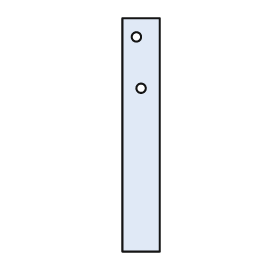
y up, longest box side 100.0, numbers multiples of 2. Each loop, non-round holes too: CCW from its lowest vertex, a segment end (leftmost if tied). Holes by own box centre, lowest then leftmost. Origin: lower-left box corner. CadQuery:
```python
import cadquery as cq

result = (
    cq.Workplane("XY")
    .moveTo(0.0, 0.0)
    .lineTo(16.0, 0.0)
    .lineTo(16.0, 100.0)
    .lineTo(0.0, 100.0)
    .close()
    .moveTo(8.0, 70.0)
    .circle(2.0)
    .moveTo(6.0, 92.0)
    .circle(2.0)
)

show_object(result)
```